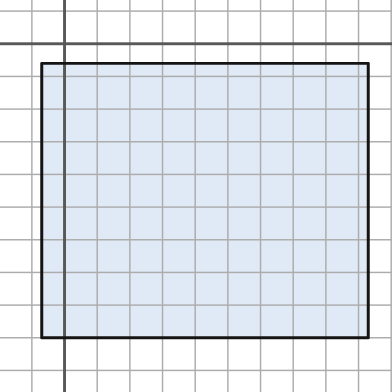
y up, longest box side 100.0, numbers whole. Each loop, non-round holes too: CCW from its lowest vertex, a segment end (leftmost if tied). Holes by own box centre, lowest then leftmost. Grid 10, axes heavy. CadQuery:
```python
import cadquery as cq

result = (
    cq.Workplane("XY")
    .moveTo(-7.0, -90.0)
    .lineTo(93.0, -90.0)
    .lineTo(93.0, -6.0)
    .lineTo(-7.0, -6.0)
    .close()
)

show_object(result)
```